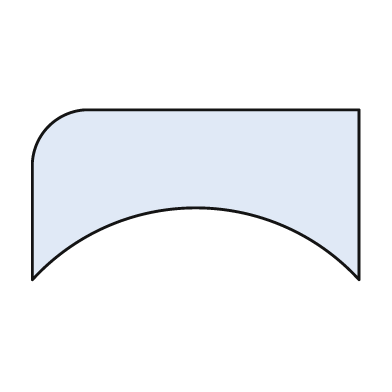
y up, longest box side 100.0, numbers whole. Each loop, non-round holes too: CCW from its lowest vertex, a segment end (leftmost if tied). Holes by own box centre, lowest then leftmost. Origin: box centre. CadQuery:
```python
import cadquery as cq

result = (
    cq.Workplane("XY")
    .moveTo(-50.0, -26.0)
    .threePointArc((0.0, -4.0), (50.0, -26.0))
    .lineTo(50.0, 26.0)
    .lineTo(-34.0, 26.0)
    .threePointArc((-45.0, 21.0), (-50.0, 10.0))
    .close()
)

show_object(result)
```